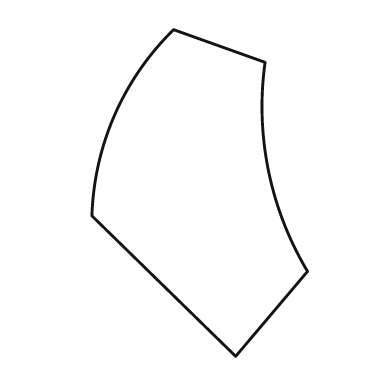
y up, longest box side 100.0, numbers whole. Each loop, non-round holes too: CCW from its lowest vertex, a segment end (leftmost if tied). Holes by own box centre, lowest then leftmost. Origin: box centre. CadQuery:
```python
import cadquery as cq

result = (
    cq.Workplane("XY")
    .moveTo(11.0, -50.0)
    .lineTo(33.0, -24.0)
    .threePointArc((21.0, 7.0), (20.0, 40.0))
    .lineTo(-8.0, 50.0)
    .threePointArc((-26.0, 24.0), (-33.0, -7.0))
    .close()
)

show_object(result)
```